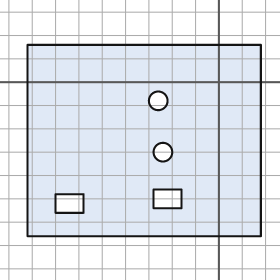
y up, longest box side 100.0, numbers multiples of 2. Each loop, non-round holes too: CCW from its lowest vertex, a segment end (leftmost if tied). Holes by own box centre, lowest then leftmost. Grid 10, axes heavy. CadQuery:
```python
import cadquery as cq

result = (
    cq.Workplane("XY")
    .moveTo(-82.0, -66.0)
    .lineTo(18.0, -66.0)
    .lineTo(18.0, 16.0)
    .lineTo(-82.0, 16.0)
    .close()
    .moveTo(-70.0, -56.0)
    .lineTo(-58.0, -56.0)
    .lineTo(-58.0, -48.0)
    .lineTo(-70.0, -48.0)
    .close()
    .moveTo(-28.0, -54.0)
    .lineTo(-16.0, -54.0)
    .lineTo(-16.0, -46.0)
    .lineTo(-28.0, -46.0)
    .close()
    .moveTo(-24.0, -30.0)
    .circle(4.0)
    .moveTo(-26.0, -8.0)
    .circle(4.0)
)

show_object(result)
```